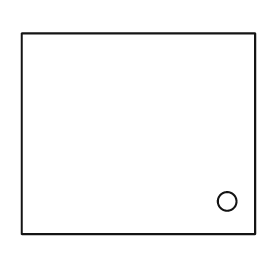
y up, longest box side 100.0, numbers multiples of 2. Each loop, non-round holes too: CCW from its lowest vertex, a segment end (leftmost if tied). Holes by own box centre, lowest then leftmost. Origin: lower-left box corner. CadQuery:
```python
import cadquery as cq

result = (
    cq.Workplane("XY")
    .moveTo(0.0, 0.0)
    .lineTo(100.0, 0.0)
    .lineTo(100.0, 86.0)
    .lineTo(0.0, 86.0)
    .close()
    .moveTo(88.0, 14.0)
    .circle(4.0)
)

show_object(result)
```